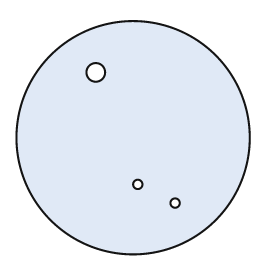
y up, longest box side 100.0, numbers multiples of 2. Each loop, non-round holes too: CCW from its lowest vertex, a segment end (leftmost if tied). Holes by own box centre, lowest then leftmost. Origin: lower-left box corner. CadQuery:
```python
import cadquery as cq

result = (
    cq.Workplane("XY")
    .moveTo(50.0, 50.0)
    .circle(50.0)
    .moveTo(68.0, 22.0)
    .circle(2.0)
    .moveTo(52.0, 30.0)
    .circle(2.0)
    .moveTo(34.0, 78.0)
    .circle(4.0)
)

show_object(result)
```